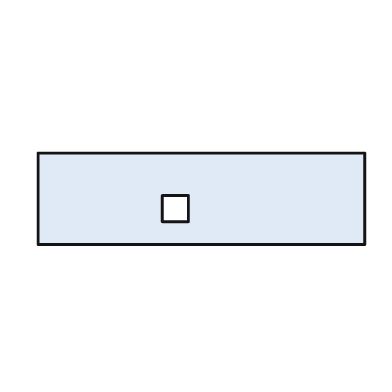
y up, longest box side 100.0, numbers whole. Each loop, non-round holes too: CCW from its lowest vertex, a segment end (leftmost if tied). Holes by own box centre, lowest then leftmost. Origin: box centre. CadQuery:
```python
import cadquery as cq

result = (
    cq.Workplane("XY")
    .moveTo(-50.0, -14.0)
    .lineTo(50.0, -14.0)
    .lineTo(50.0, 14.0)
    .lineTo(-50.0, 14.0)
    .close()
    .moveTo(-12.0, -7.0)
    .lineTo(-4.0, -7.0)
    .lineTo(-4.0, 1.0)
    .lineTo(-12.0, 1.0)
    .close()
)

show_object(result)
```